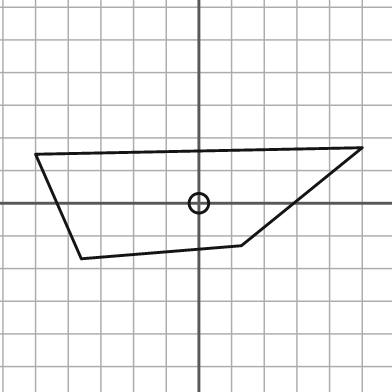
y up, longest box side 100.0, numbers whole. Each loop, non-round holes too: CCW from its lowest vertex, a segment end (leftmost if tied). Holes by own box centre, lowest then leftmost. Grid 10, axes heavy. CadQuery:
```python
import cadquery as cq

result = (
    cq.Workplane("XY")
    .moveTo(-36.0, -17.0)
    .lineTo(13.0, -13.0)
    .lineTo(50.0, 17.0)
    .lineTo(-50.0, 15.0)
    .close()
    .moveTo(0.0, 0.0)
    .circle(3.0)
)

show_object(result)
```